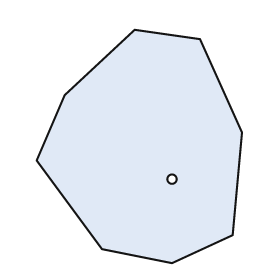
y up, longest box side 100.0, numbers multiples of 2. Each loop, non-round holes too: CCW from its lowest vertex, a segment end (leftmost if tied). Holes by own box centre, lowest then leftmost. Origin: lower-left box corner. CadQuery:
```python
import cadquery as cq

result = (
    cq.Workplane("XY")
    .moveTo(58.0, 0.0)
    .lineTo(84.0, 12.0)
    .lineTo(88.0, 56.0)
    .lineTo(70.0, 96.0)
    .lineTo(42.0, 100.0)
    .lineTo(12.0, 72.0)
    .lineTo(0.0, 44.0)
    .lineTo(28.0, 6.0)
    .close()
    .moveTo(58.0, 36.0)
    .circle(2.0)
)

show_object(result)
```